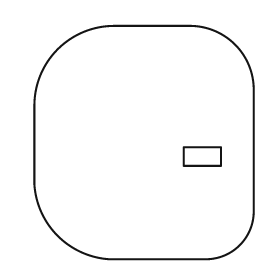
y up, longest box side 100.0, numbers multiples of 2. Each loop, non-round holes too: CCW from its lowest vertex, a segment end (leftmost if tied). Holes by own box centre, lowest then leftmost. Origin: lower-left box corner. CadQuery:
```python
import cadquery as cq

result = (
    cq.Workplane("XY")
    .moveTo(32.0, 0.0)
    .lineTo(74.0, 0.0)
    .threePointArc((88.0, 6.0), (94.0, 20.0))
    .lineTo(94.0, 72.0)
    .threePointArc((86.0, 92.0), (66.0, 100.0))
    .lineTo(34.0, 100.0)
    .threePointArc((10.0, 90.0), (0.0, 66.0))
    .lineTo(0.0, 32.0)
    .threePointArc((10.0, 10.0), (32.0, 0.0))
    .close()
    .moveTo(64.0, 40.0)
    .lineTo(80.0, 40.0)
    .lineTo(80.0, 48.0)
    .lineTo(64.0, 48.0)
    .close()
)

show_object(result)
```